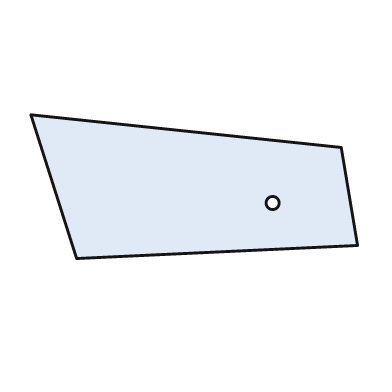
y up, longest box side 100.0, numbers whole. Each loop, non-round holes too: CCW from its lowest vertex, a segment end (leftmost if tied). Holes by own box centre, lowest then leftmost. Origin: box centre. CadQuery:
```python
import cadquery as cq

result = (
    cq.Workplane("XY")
    .moveTo(-36.0, -22.0)
    .lineTo(50.0, -18.0)
    .lineTo(45.0, 12.0)
    .lineTo(-50.0, 22.0)
    .close()
    .moveTo(24.0, -5.0)
    .circle(2.0)
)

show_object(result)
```